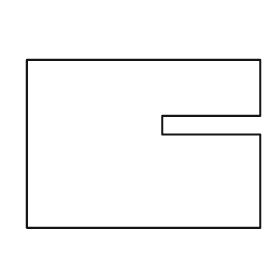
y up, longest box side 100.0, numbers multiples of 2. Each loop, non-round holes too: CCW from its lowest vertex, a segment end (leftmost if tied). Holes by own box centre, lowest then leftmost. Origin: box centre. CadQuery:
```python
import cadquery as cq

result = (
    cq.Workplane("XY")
    .moveTo(-50.0, -36.0)
    .lineTo(50.0, -36.0)
    .lineTo(50.0, 4.0)
    .lineTo(8.0, 4.0)
    .lineTo(8.0, 12.0)
    .lineTo(50.0, 12.0)
    .lineTo(50.0, 36.0)
    .lineTo(-50.0, 36.0)
    .close()
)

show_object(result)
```